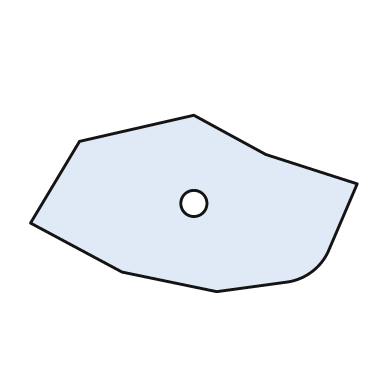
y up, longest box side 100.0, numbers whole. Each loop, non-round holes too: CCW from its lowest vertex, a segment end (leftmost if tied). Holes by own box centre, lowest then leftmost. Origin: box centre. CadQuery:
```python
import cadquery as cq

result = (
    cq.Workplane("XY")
    .moveTo(7.0, -27.0)
    .lineTo(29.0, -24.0)
    .threePointArc((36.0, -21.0), (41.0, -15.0))
    .lineTo(50.0, 6.0)
    .lineTo(22.0, 15.0)
    .lineTo(0.0, 27.0)
    .lineTo(-35.0, 19.0)
    .lineTo(-50.0, -6.0)
    .lineTo(-22.0, -21.0)
    .close()
    .moveTo(0.0, 0.0)
    .circle(4.0)
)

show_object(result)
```